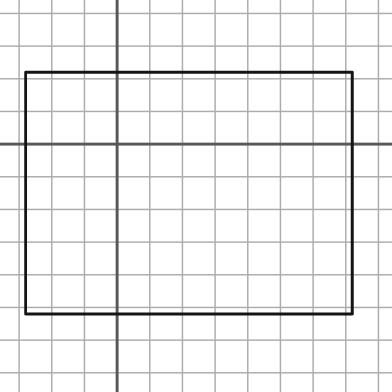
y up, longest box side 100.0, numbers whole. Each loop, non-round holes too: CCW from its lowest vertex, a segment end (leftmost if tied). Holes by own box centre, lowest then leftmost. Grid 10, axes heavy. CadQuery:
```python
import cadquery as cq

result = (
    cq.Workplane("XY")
    .moveTo(-28.0, -52.0)
    .lineTo(72.0, -52.0)
    .lineTo(72.0, 22.0)
    .lineTo(-28.0, 22.0)
    .close()
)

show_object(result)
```